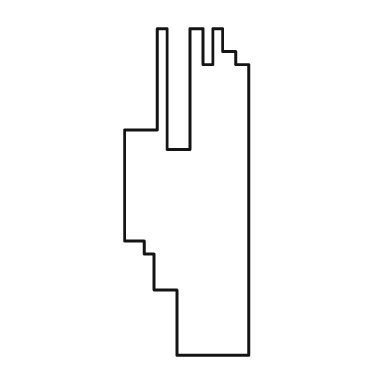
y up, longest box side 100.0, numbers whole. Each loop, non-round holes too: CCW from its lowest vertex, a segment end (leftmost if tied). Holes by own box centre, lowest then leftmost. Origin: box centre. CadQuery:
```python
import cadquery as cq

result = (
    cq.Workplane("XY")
    .moveTo(-3.0, -50.0)
    .lineTo(19.0, -50.0)
    .lineTo(19.0, 39.0)
    .lineTo(15.0, 39.0)
    .lineTo(15.0, 43.0)
    .lineTo(11.0, 43.0)
    .lineTo(11.0, 50.0)
    .lineTo(8.0, 50.0)
    .lineTo(8.0, 39.0)
    .lineTo(5.0, 39.0)
    .lineTo(5.0, 50.0)
    .lineTo(1.0, 50.0)
    .lineTo(1.0, 13.0)
    .lineTo(-6.0, 13.0)
    .lineTo(-6.0, 50.0)
    .lineTo(-9.0, 50.0)
    .lineTo(-9.0, 19.0)
    .lineTo(-19.0, 19.0)
    .lineTo(-19.0, -15.0)
    .lineTo(-13.0, -15.0)
    .lineTo(-13.0, -19.0)
    .lineTo(-10.0, -19.0)
    .lineTo(-10.0, -30.0)
    .lineTo(-3.0, -30.0)
    .close()
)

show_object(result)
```